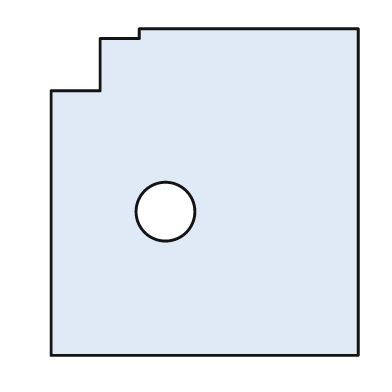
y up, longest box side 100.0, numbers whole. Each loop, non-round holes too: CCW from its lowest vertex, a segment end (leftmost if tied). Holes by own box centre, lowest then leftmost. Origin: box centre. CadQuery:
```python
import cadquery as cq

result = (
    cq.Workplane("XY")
    .moveTo(-47.0, -50.0)
    .lineTo(47.0, -50.0)
    .lineTo(47.0, 50.0)
    .lineTo(-20.0, 50.0)
    .lineTo(-20.0, 47.0)
    .lineTo(-32.0, 47.0)
    .lineTo(-32.0, 31.0)
    .lineTo(-47.0, 31.0)
    .close()
    .moveTo(-12.0, -6.0)
    .circle(9.0)
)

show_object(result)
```